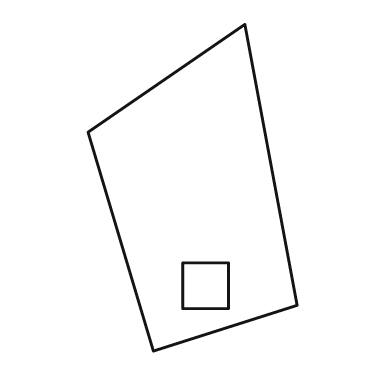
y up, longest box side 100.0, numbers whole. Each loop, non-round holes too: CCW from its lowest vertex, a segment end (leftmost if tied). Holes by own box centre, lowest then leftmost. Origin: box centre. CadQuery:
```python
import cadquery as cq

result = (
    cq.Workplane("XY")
    .moveTo(-12.0, -50.0)
    .lineTo(32.0, -36.0)
    .lineTo(16.0, 50.0)
    .lineTo(-32.0, 17.0)
    .close()
    .moveTo(-3.0, -37.0)
    .lineTo(11.0, -37.0)
    .lineTo(11.0, -23.0)
    .lineTo(-3.0, -23.0)
    .close()
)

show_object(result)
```